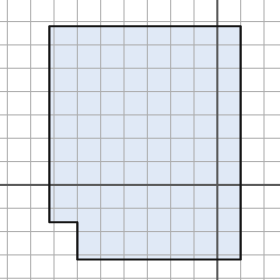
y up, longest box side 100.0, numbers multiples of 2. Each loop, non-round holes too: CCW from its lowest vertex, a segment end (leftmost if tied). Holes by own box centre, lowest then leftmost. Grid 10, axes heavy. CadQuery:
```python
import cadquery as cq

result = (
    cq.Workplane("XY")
    .moveTo(-60.0, -32.0)
    .lineTo(10.0, -32.0)
    .lineTo(10.0, 68.0)
    .lineTo(-72.0, 68.0)
    .lineTo(-72.0, -16.0)
    .lineTo(-60.0, -16.0)
    .close()
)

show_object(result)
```